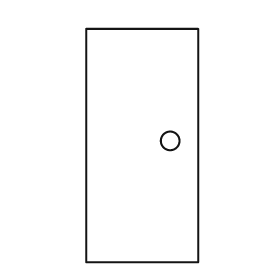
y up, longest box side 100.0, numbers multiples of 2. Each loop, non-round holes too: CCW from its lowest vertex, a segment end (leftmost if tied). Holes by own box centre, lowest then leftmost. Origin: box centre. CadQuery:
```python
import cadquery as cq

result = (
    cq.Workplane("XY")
    .moveTo(-24.0, -50.0)
    .lineTo(24.0, -50.0)
    .lineTo(24.0, 50.0)
    .lineTo(-24.0, 50.0)
    .close()
    .moveTo(12.0, 2.0)
    .circle(4.0)
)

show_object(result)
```